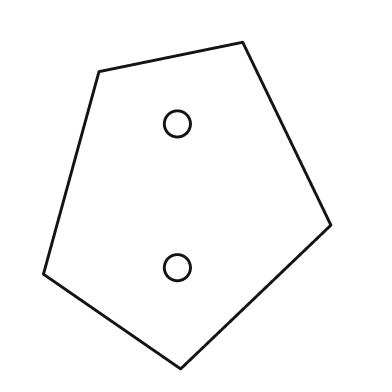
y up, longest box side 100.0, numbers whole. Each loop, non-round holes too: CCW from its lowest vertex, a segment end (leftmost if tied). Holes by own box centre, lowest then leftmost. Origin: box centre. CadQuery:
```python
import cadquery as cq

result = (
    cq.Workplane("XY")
    .moveTo(-2.0, -50.0)
    .lineTo(44.0, -6.0)
    .lineTo(17.0, 50.0)
    .lineTo(-27.0, 41.0)
    .lineTo(-44.0, -21.0)
    .close()
    .moveTo(-3.0, -19.0)
    .circle(4.0)
    .moveTo(-3.0, 25.0)
    .circle(4.0)
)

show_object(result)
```